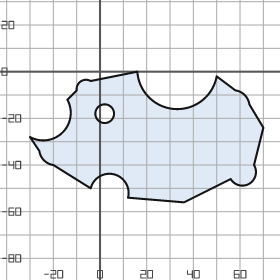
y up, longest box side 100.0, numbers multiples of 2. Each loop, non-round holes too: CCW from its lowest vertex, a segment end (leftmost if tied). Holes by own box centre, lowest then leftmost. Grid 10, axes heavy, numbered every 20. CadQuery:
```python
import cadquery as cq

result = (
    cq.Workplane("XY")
    .moveTo(36.0, -56.0)
    .lineTo(56.0, -46.0)
    .threePointArc((64.0, -48.0), (66.0, -40.0))
    .lineTo(70.0, -24.0)
    .lineTo(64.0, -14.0)
    .threePointArc((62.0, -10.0), (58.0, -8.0))
    .lineTo(50.0, -2.0)
    .threePointArc((32.0, -16.0), (16.0, 0.0))
    .lineTo(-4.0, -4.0)
    .threePointArc((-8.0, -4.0), (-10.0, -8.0))
    .lineTo(-14.0, -12.0)
    .threePointArc((-16.0, -26.0), (-30.0, -28.0))
    .lineTo(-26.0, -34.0)
    .threePointArc((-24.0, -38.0), (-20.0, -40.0))
    .lineTo(-4.0, -50.0)
    .threePointArc((6.0, -44.0), (12.0, -54.0))
    .close()
    .moveTo(2.0, -18.0)
    .circle(4.0)
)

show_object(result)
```